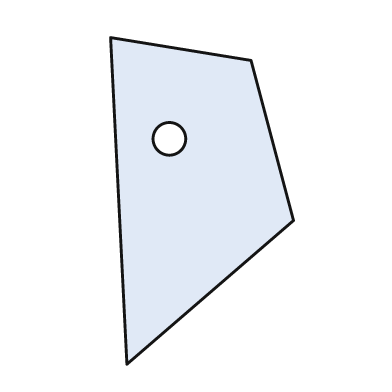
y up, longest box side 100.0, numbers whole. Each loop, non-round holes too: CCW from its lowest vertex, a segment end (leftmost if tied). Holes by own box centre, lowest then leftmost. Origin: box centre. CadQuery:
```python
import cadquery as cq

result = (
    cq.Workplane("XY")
    .moveTo(-23.0, -50.0)
    .lineTo(28.0, -6.0)
    .lineTo(15.0, 43.0)
    .lineTo(-28.0, 50.0)
    .close()
    .moveTo(-10.0, 19.0)
    .circle(5.0)
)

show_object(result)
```